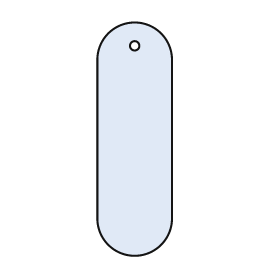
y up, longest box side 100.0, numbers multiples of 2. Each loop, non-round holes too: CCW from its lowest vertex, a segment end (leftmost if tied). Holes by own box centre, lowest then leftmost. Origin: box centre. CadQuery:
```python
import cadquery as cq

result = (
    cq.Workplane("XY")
    .moveTo(-16.0, -34.0)
    .threePointArc((0.0, -50.0), (16.0, -34.0))
    .lineTo(16.0, 34.0)
    .threePointArc((0.0, 50.0), (-16.0, 34.0))
    .close()
    .moveTo(0.0, 40.0)
    .circle(2.0)
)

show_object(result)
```